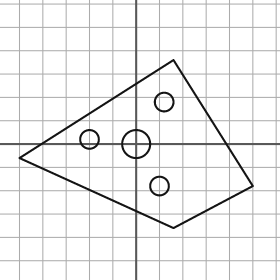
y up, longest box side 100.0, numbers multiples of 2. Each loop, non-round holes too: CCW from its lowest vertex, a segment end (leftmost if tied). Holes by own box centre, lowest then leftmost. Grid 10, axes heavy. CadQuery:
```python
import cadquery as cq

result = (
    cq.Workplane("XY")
    .moveTo(16.0, -36.0)
    .lineTo(50.0, -18.0)
    .lineTo(16.0, 36.0)
    .lineTo(-50.0, -6.0)
    .close()
    .moveTo(10.0, -18.0)
    .circle(4.0)
    .moveTo(0.0, 0.0)
    .circle(6.0)
    .moveTo(-20.0, 2.0)
    .circle(4.0)
    .moveTo(12.0, 18.0)
    .circle(4.0)
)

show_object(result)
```